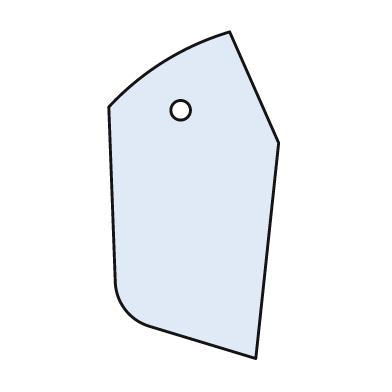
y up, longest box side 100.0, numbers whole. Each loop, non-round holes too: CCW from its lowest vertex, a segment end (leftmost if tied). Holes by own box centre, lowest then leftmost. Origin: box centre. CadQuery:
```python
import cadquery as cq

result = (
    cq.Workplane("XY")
    .moveTo(19.0, -50.0)
    .lineTo(26.0, 16.0)
    .lineTo(11.0, 50.0)
    .threePointArc((-9.0, 41.0), (-26.0, 27.0))
    .lineTo(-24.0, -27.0)
    .threePointArc((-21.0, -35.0), (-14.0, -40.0))
    .close()
    .moveTo(-4.0, 26.0)
    .circle(3.0)
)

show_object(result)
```